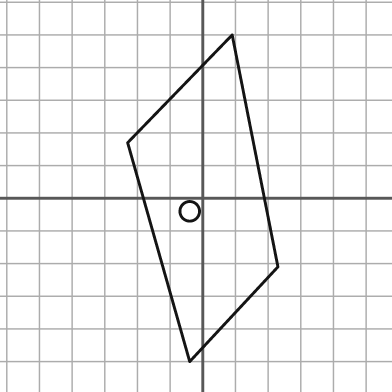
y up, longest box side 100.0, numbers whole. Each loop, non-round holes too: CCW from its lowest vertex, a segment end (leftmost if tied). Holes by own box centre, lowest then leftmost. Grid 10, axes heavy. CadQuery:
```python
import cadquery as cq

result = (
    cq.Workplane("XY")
    .moveTo(-4.0, -50.0)
    .lineTo(23.0, -21.0)
    .lineTo(9.0, 50.0)
    .lineTo(-23.0, 17.0)
    .close()
    .moveTo(-4.0, -4.0)
    .circle(3.0)
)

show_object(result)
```